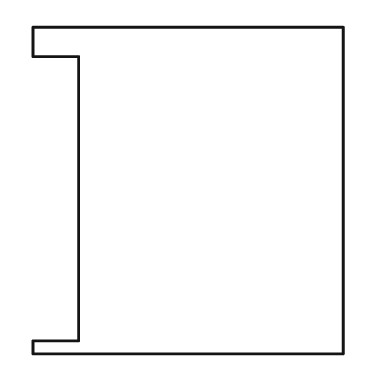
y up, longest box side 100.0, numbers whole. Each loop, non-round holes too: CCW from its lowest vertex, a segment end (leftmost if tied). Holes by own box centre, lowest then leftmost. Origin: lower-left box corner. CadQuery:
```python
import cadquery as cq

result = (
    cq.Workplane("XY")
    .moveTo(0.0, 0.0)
    .lineTo(95.0, 0.0)
    .lineTo(95.0, 100.0)
    .lineTo(0.0, 100.0)
    .lineTo(0.0, 91.0)
    .lineTo(14.0, 91.0)
    .lineTo(14.0, 4.0)
    .lineTo(0.0, 4.0)
    .close()
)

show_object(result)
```